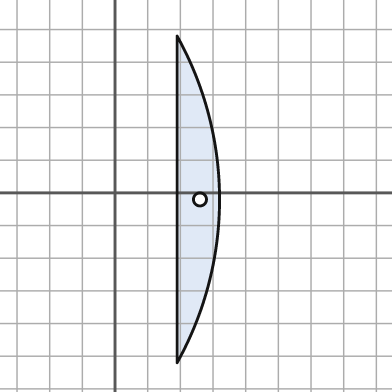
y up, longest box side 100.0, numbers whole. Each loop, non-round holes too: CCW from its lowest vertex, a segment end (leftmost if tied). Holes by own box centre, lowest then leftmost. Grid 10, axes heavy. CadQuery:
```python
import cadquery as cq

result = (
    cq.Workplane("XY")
    .moveTo(19.0, -52.0)
    .threePointArc((32.0, -2.0), (19.0, 48.0))
    .close()
    .moveTo(26.0, -2.0)
    .circle(2.0)
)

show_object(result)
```